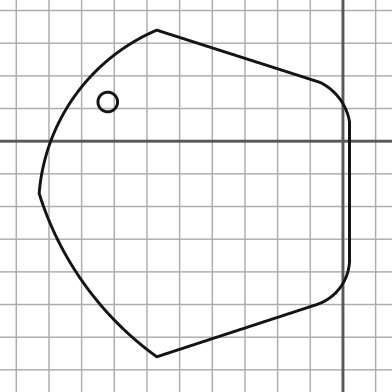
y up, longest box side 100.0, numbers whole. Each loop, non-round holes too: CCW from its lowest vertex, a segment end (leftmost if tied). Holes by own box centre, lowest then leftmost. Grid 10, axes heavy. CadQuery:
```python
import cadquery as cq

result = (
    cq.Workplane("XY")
    .moveTo(-57.0, -66.0)
    .lineTo(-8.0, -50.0)
    .threePointArc((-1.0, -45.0), (2.0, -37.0))
    .lineTo(2.0, 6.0)
    .threePointArc((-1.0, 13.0), (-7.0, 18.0))
    .lineTo(-57.0, 34.0)
    .threePointArc((-82.0, 14.0), (-93.0, -16.0))
    .threePointArc((-79.0, -44.0), (-57.0, -66.0))
    .close()
    .moveTo(-72.0, 12.0)
    .circle(3.0)
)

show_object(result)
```